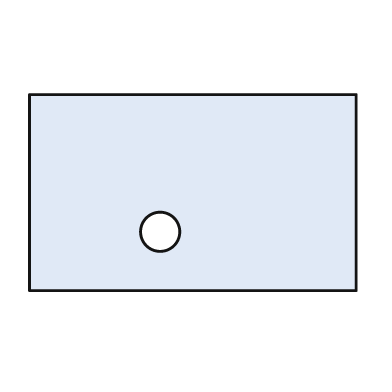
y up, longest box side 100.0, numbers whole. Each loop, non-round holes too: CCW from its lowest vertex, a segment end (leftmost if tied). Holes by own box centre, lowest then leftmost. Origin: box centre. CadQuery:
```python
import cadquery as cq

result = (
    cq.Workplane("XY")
    .moveTo(-50.0, -30.0)
    .lineTo(50.0, -30.0)
    .lineTo(50.0, 30.0)
    .lineTo(-50.0, 30.0)
    .close()
    .moveTo(-10.0, -12.0)
    .circle(6.0)
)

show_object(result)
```